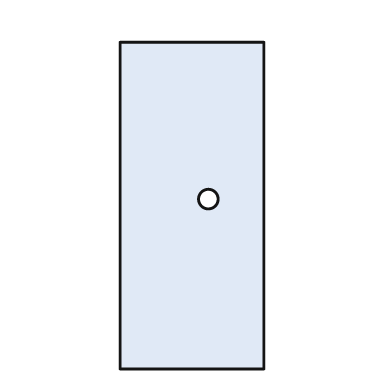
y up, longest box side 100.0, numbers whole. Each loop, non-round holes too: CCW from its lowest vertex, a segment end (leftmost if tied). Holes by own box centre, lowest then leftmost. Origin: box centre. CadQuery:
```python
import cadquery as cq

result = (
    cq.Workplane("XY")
    .moveTo(-22.0, -50.0)
    .lineTo(22.0, -50.0)
    .lineTo(22.0, 50.0)
    .lineTo(-22.0, 50.0)
    .close()
    .moveTo(5.0, 2.0)
    .circle(3.0)
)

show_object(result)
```